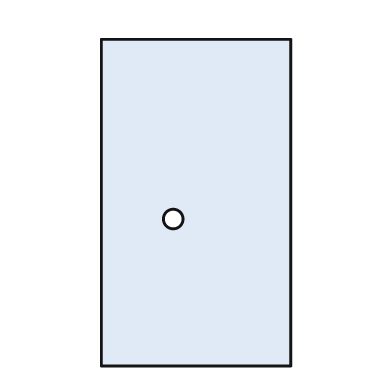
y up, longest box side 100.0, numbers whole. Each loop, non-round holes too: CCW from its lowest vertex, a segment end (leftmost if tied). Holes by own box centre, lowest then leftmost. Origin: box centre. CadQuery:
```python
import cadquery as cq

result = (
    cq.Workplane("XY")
    .moveTo(-29.0, -50.0)
    .lineTo(29.0, -50.0)
    .lineTo(29.0, 50.0)
    .lineTo(-29.0, 50.0)
    .close()
    .moveTo(-7.0, -5.0)
    .circle(3.0)
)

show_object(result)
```